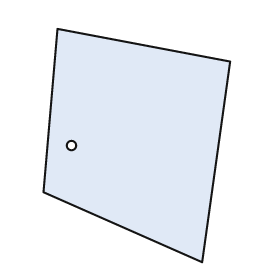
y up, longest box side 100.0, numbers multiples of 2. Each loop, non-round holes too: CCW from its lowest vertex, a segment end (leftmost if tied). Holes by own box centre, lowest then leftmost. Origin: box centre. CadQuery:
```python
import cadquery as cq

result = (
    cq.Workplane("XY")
    .moveTo(28.0, -50.0)
    .lineTo(40.0, 36.0)
    .lineTo(-34.0, 50.0)
    .lineTo(-40.0, -20.0)
    .close()
    .moveTo(-28.0, 0.0)
    .circle(2.0)
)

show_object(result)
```